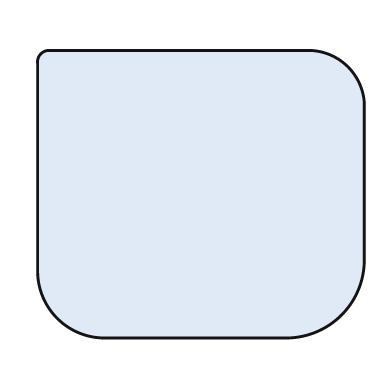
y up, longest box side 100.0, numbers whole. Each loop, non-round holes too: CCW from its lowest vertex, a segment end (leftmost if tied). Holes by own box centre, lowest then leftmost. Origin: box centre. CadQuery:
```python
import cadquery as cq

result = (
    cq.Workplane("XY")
    .moveTo(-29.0, -44.0)
    .lineTo(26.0, -44.0)
    .threePointArc((43.0, -37.0), (50.0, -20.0))
    .lineTo(50.0, 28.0)
    .threePointArc((45.0, 39.0), (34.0, 44.0))
    .lineTo(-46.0, 44.0)
    .threePointArc((-49.0, 43.0), (-50.0, 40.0))
    .lineTo(-50.0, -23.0)
    .threePointArc((-44.0, -38.0), (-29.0, -44.0))
    .close()
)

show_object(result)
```